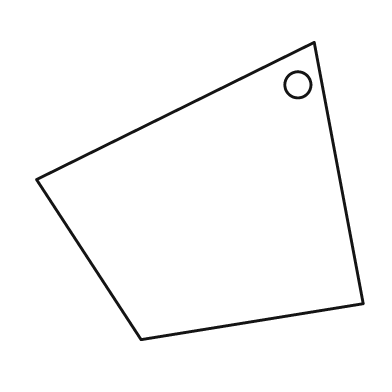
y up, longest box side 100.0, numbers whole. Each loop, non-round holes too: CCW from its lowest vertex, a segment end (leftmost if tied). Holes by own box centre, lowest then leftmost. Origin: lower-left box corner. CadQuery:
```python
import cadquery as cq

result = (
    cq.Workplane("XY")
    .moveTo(32.0, 0.0)
    .lineTo(100.0, 11.0)
    .lineTo(85.0, 91.0)
    .lineTo(0.0, 49.0)
    .close()
    .moveTo(80.0, 78.0)
    .circle(4.0)
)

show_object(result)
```